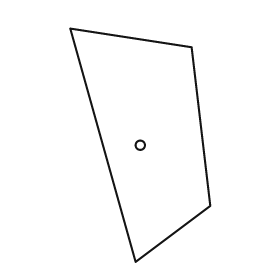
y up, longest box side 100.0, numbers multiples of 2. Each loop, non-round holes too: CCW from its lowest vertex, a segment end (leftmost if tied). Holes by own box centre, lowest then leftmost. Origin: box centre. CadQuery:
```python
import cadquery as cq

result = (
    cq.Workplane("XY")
    .moveTo(-2.0, -50.0)
    .lineTo(30.0, -26.0)
    .lineTo(22.0, 42.0)
    .lineTo(-30.0, 50.0)
    .close()
    .moveTo(0.0, 0.0)
    .circle(2.0)
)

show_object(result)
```